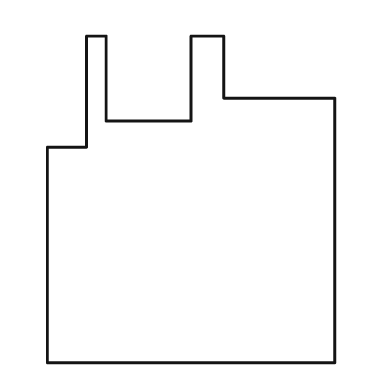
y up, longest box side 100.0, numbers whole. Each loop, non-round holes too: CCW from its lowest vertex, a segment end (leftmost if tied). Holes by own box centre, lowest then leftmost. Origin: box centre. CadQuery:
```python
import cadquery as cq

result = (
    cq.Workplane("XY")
    .moveTo(-44.0, -50.0)
    .lineTo(44.0, -50.0)
    .lineTo(44.0, 31.0)
    .lineTo(10.0, 31.0)
    .lineTo(10.0, 50.0)
    .lineTo(0.0, 50.0)
    .lineTo(0.0, 24.0)
    .lineTo(-26.0, 24.0)
    .lineTo(-26.0, 50.0)
    .lineTo(-32.0, 50.0)
    .lineTo(-32.0, 16.0)
    .lineTo(-44.0, 16.0)
    .close()
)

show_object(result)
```